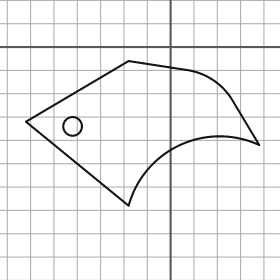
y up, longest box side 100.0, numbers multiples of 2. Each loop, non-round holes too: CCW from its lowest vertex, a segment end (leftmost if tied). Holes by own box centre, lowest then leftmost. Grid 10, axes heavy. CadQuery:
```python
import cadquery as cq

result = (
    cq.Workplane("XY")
    .moveTo(-18.0, -68.0)
    .threePointArc((4.0, -42.0), (38.0, -42.0))
    .lineTo(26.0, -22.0)
    .threePointArc((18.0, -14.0), (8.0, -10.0))
    .lineTo(-18.0, -6.0)
    .lineTo(-62.0, -32.0)
    .close()
    .moveTo(-42.0, -34.0)
    .circle(4.0)
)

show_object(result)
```